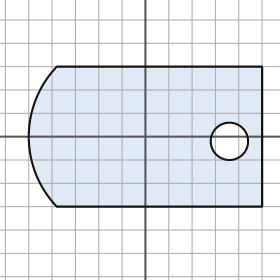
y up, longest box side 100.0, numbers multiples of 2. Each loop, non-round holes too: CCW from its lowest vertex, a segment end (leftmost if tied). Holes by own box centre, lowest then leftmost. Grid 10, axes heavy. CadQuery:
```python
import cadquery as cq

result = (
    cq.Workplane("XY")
    .moveTo(-38.0, -30.0)
    .lineTo(50.0, -30.0)
    .lineTo(50.0, 30.0)
    .lineTo(-38.0, 30.0)
    .threePointArc((-50.0, 0.0), (-38.0, -30.0))
    .close()
    .moveTo(36.0, -2.0)
    .circle(8.0)
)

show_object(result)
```